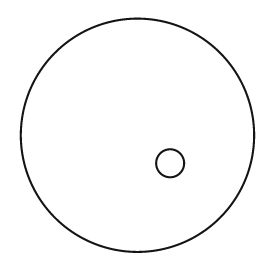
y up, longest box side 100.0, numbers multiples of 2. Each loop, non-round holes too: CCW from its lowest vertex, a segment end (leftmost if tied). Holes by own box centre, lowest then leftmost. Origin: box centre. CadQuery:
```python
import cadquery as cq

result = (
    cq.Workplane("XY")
    .moveTo(0.0, 0.0)
    .circle(50.0)
    .moveTo(14.0, -12.0)
    .circle(6.0)
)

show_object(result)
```